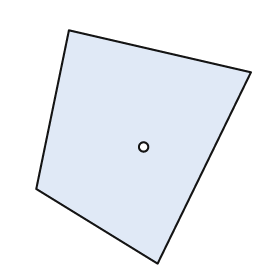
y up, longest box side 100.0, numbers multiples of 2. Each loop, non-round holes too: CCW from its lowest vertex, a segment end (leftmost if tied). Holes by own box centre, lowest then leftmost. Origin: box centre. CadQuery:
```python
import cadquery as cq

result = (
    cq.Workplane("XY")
    .moveTo(6.0, -50.0)
    .lineTo(46.0, 32.0)
    .lineTo(-32.0, 50.0)
    .lineTo(-46.0, -18.0)
    .close()
    .moveTo(0.0, 0.0)
    .circle(2.0)
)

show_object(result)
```